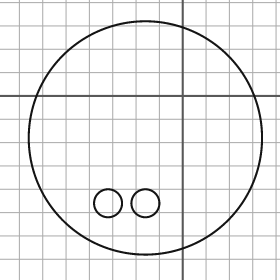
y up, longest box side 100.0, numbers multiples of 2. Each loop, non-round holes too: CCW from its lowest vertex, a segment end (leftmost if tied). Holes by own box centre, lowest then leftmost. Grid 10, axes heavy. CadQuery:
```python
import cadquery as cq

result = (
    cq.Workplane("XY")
    .moveTo(-16.0, -18.0)
    .circle(50.0)
    .moveTo(-32.0, -46.0)
    .circle(6.0)
    .moveTo(-16.0, -46.0)
    .circle(6.0)
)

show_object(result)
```